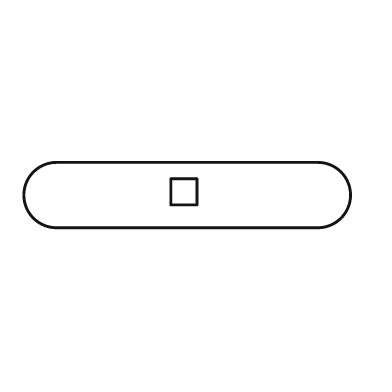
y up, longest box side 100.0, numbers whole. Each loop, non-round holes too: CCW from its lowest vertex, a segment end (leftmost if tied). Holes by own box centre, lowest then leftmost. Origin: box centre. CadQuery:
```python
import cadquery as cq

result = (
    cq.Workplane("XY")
    .moveTo(-40.0, -10.0)
    .lineTo(40.0, -10.0)
    .threePointArc((50.0, 0.0), (40.0, 10.0))
    .lineTo(-40.0, 10.0)
    .threePointArc((-50.0, 0.0), (-40.0, -10.0))
    .close()
    .moveTo(-5.0, -3.0)
    .lineTo(3.0, -3.0)
    .lineTo(3.0, 5.0)
    .lineTo(-5.0, 5.0)
    .close()
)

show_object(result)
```